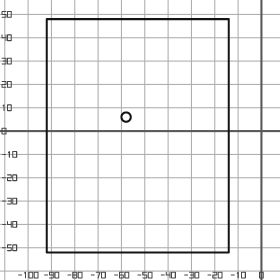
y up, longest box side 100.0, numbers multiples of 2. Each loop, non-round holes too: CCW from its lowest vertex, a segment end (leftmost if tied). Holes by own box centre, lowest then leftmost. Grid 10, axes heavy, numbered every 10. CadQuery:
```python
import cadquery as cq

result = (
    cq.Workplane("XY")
    .moveTo(-92.0, -52.0)
    .lineTo(-14.0, -52.0)
    .lineTo(-14.0, 48.0)
    .lineTo(-92.0, 48.0)
    .close()
    .moveTo(-58.0, 6.0)
    .circle(2.0)
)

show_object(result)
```